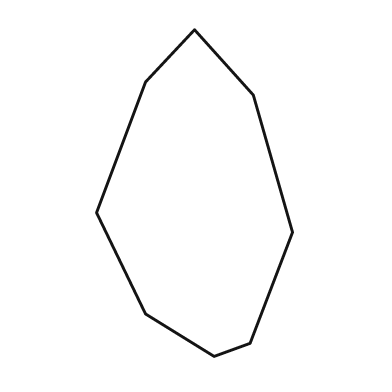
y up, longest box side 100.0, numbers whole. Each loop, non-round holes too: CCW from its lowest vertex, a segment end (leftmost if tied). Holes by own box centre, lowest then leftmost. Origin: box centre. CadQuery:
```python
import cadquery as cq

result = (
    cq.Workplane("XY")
    .moveTo(6.0, -50.0)
    .lineTo(17.0, -46.0)
    .lineTo(30.0, -12.0)
    .lineTo(18.0, 30.0)
    .lineTo(0.0, 50.0)
    .lineTo(-15.0, 34.0)
    .lineTo(-30.0, -6.0)
    .lineTo(-15.0, -37.0)
    .close()
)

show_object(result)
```